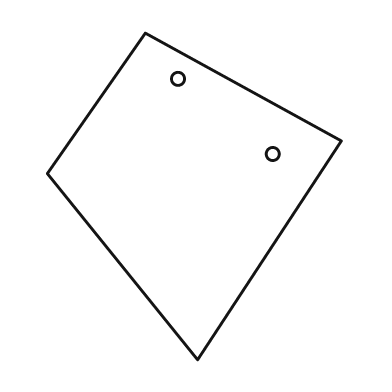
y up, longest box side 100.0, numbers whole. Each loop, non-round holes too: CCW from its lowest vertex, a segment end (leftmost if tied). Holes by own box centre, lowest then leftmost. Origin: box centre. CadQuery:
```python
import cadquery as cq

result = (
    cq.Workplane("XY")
    .moveTo(1.0, -50.0)
    .lineTo(45.0, 17.0)
    .lineTo(-15.0, 50.0)
    .lineTo(-45.0, 7.0)
    .close()
    .moveTo(24.0, 13.0)
    .circle(2.0)
    .moveTo(-5.0, 36.0)
    .circle(2.0)
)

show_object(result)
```